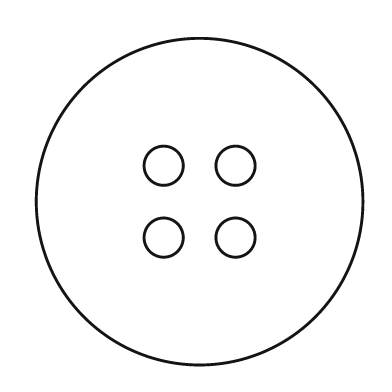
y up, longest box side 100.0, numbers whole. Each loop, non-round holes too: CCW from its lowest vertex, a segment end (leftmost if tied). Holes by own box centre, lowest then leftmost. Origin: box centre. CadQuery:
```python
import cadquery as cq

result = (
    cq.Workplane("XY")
    .moveTo(0.0, 0.0)
    .circle(50.0)
    .moveTo(-11.0, -11.0)
    .circle(6.0)
    .moveTo(11.0, -11.0)
    .circle(6.0)
    .moveTo(-11.0, 11.0)
    .circle(6.0)
    .moveTo(11.0, 11.0)
    .circle(6.0)
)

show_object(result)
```